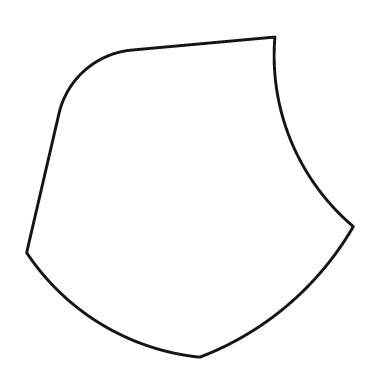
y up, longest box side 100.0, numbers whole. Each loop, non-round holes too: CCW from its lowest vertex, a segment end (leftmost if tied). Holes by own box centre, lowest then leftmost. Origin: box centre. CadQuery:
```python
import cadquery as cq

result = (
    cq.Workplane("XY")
    .moveTo(3.0, -49.0)
    .threePointArc((30.0, -33.0), (50.0, -9.0))
    .threePointArc((31.0, 17.0), (26.0, 49.0))
    .lineTo(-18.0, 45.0)
    .threePointArc((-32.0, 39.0), (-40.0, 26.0))
    .lineTo(-50.0, -17.0)
    .threePointArc((-27.0, -39.0), (3.0, -49.0))
    .close()
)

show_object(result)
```